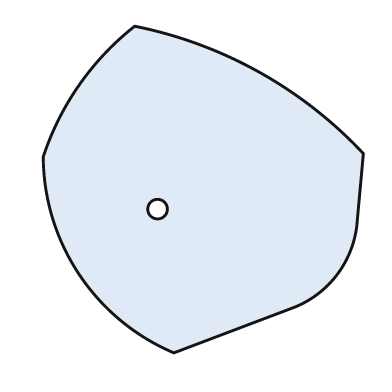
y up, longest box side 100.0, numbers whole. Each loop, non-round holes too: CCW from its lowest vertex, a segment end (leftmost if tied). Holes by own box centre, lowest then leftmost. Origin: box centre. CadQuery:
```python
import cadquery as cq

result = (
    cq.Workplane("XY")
    .moveTo(-9.0, -50.0)
    .lineTo(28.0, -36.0)
    .threePointArc((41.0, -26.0), (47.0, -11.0))
    .lineTo(49.0, 11.0)
    .threePointArc((17.0, 36.0), (-21.0, 50.0))
    .threePointArc((-38.0, 32.0), (-49.0, 10.0))
    .threePointArc((-38.0, -26.0), (-9.0, -50.0))
    .close()
    .moveTo(-14.0, -6.0)
    .circle(3.0)
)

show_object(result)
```